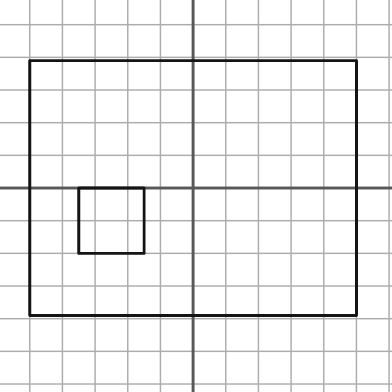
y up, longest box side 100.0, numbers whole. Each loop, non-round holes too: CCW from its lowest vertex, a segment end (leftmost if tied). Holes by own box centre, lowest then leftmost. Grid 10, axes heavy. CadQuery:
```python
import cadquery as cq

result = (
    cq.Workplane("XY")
    .moveTo(-50.0, -39.0)
    .lineTo(50.0, -39.0)
    .lineTo(50.0, 39.0)
    .lineTo(-50.0, 39.0)
    .close()
    .moveTo(-35.0, -20.0)
    .lineTo(-15.0, -20.0)
    .lineTo(-15.0, 0.0)
    .lineTo(-35.0, 0.0)
    .close()
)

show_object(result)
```